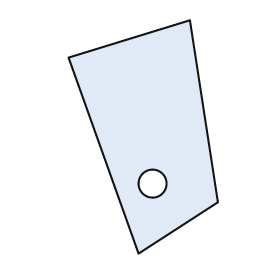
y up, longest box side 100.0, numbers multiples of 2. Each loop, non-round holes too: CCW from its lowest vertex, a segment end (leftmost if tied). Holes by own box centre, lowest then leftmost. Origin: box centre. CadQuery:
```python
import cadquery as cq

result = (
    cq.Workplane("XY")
    .moveTo(-2.0, -50.0)
    .lineTo(32.0, -28.0)
    .lineTo(20.0, 50.0)
    .lineTo(-32.0, 34.0)
    .close()
    .moveTo(4.0, -20.0)
    .circle(6.0)
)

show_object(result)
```